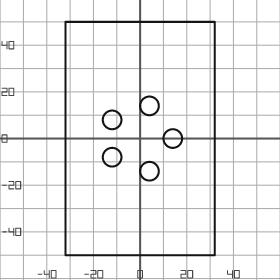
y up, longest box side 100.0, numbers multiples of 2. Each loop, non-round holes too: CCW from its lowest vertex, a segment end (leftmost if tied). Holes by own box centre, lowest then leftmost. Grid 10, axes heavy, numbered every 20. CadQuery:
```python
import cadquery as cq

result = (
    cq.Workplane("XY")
    .moveTo(-32.0, -50.0)
    .lineTo(32.0, -50.0)
    .lineTo(32.0, 50.0)
    .lineTo(-32.0, 50.0)
    .close()
    .moveTo(4.0, -14.0)
    .circle(4.0)
    .moveTo(-12.0, -8.0)
    .circle(4.0)
    .moveTo(14.0, 0.0)
    .circle(4.0)
    .moveTo(-12.0, 8.0)
    .circle(4.0)
    .moveTo(4.0, 14.0)
    .circle(4.0)
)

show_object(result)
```